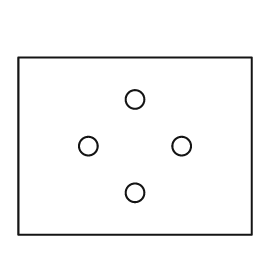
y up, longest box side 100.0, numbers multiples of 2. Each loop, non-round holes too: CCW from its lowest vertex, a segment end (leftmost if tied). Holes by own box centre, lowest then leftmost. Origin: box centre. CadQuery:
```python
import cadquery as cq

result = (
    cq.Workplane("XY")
    .moveTo(-50.0, -38.0)
    .lineTo(50.0, -38.0)
    .lineTo(50.0, 38.0)
    .lineTo(-50.0, 38.0)
    .close()
    .moveTo(0.0, -20.0)
    .circle(4.0)
    .moveTo(-20.0, 0.0)
    .circle(4.0)
    .moveTo(20.0, 0.0)
    .circle(4.0)
    .moveTo(0.0, 20.0)
    .circle(4.0)
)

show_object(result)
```